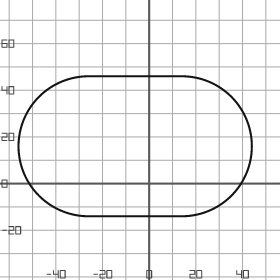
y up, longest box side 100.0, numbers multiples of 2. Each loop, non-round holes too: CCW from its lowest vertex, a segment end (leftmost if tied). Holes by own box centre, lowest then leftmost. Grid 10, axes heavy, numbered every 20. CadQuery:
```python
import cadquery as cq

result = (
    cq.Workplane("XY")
    .moveTo(-26.0, -14.0)
    .lineTo(14.0, -14.0)
    .threePointArc((44.0, 16.0), (14.0, 46.0))
    .lineTo(-26.0, 46.0)
    .threePointArc((-56.0, 16.0), (-26.0, -14.0))
    .close()
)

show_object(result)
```